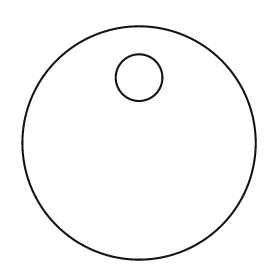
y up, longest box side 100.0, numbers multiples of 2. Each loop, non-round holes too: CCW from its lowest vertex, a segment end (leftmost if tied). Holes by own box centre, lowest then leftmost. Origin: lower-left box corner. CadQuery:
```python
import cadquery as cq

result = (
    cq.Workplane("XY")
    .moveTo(50.0, 50.0)
    .circle(50.0)
    .moveTo(50.0, 78.0)
    .circle(10.0)
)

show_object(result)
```